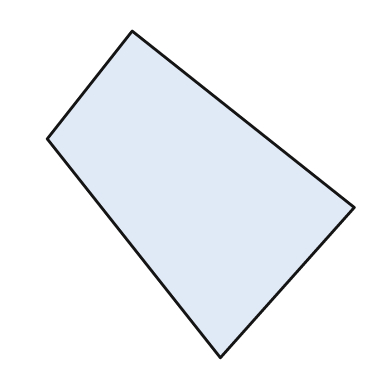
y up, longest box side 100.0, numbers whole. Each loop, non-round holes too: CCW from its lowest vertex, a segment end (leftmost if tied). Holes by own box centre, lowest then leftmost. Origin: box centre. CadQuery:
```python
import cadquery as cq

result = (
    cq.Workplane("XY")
    .moveTo(6.0, -50.0)
    .lineTo(47.0, -4.0)
    .lineTo(-21.0, 50.0)
    .lineTo(-47.0, 17.0)
    .close()
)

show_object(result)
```